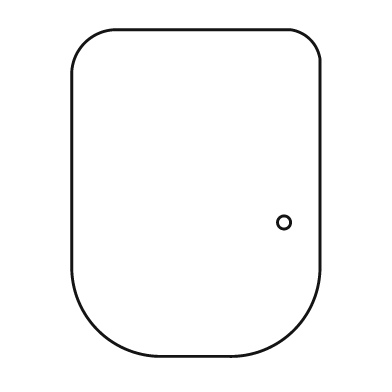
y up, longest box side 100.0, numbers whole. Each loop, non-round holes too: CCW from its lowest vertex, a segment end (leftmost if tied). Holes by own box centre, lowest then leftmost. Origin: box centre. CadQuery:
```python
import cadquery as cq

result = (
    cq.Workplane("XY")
    .moveTo(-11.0, -50.0)
    .lineTo(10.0, -50.0)
    .threePointArc((30.0, -42.0), (38.0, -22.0))
    .lineTo(38.0, 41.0)
    .threePointArc((35.0, 47.0), (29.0, 50.0))
    .lineTo(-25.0, 50.0)
    .threePointArc((-34.0, 46.0), (-38.0, 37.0))
    .lineTo(-38.0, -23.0)
    .threePointArc((-30.0, -42.0), (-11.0, -50.0))
    .close()
    .moveTo(27.0, -9.0)
    .circle(2.0)
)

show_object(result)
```